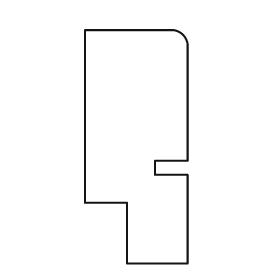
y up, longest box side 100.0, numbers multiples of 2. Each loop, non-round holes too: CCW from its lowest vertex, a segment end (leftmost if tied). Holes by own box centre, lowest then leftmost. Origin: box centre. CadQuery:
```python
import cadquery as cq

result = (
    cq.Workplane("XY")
    .moveTo(-4.0, -50.0)
    .lineTo(22.0, -50.0)
    .lineTo(22.0, -12.0)
    .lineTo(8.0, -12.0)
    .lineTo(8.0, -6.0)
    .lineTo(22.0, -6.0)
    .lineTo(22.0, 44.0)
    .threePointArc((20.0, 48.0), (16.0, 50.0))
    .lineTo(-22.0, 50.0)
    .lineTo(-22.0, -24.0)
    .lineTo(-4.0, -24.0)
    .close()
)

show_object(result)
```